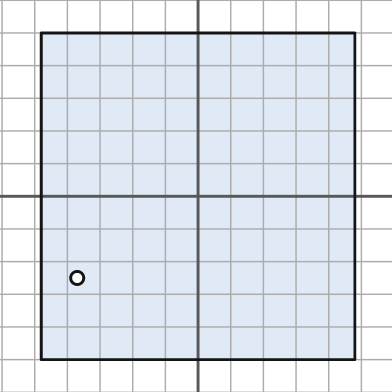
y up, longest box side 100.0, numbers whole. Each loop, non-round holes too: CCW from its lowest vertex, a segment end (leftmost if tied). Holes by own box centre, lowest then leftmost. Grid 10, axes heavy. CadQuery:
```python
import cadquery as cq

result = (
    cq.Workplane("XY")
    .moveTo(-48.0, -50.0)
    .lineTo(48.0, -50.0)
    .lineTo(48.0, 50.0)
    .lineTo(-48.0, 50.0)
    .close()
    .moveTo(-37.0, -25.0)
    .circle(2.0)
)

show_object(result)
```